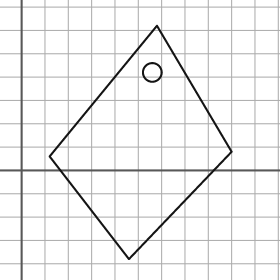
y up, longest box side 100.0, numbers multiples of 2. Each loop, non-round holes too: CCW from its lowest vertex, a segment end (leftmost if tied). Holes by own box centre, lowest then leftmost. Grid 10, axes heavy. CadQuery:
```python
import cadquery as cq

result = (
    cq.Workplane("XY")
    .moveTo(46.0, -38.0)
    .lineTo(90.0, 8.0)
    .lineTo(58.0, 62.0)
    .lineTo(12.0, 6.0)
    .close()
    .moveTo(56.0, 42.0)
    .circle(4.0)
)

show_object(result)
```